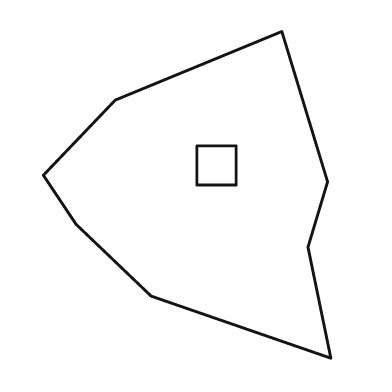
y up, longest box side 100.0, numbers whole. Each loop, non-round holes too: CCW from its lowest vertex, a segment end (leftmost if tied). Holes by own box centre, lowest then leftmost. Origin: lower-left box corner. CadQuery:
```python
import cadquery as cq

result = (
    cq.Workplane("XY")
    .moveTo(88.0, 0.0)
    .lineTo(81.0, 34.0)
    .lineTo(87.0, 54.0)
    .lineTo(73.0, 100.0)
    .lineTo(22.0, 79.0)
    .lineTo(0.0, 56.0)
    .lineTo(10.0, 41.0)
    .lineTo(33.0, 19.0)
    .close()
    .moveTo(47.0, 53.0)
    .lineTo(59.0, 53.0)
    .lineTo(59.0, 65.0)
    .lineTo(47.0, 65.0)
    .close()
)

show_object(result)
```